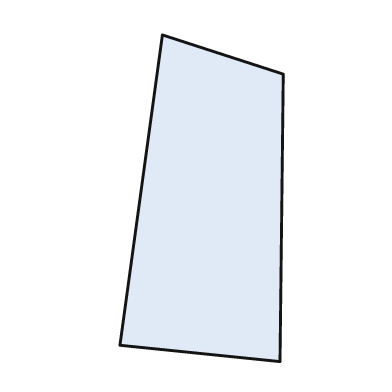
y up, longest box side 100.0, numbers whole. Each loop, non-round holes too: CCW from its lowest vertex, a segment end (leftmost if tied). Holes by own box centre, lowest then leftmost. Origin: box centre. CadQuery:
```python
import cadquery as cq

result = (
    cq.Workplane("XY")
    .moveTo(24.0, -50.0)
    .lineTo(25.0, 38.0)
    .lineTo(-12.0, 50.0)
    .lineTo(-25.0, -45.0)
    .close()
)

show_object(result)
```